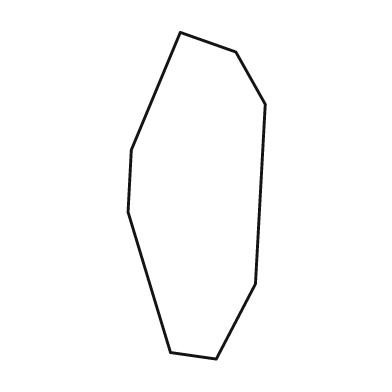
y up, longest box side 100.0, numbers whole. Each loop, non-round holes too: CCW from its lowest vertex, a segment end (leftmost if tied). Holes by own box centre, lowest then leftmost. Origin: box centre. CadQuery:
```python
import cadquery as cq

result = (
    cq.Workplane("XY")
    .moveTo(6.0, -50.0)
    .lineTo(18.0, -27.0)
    .lineTo(21.0, 28.0)
    .lineTo(12.0, 44.0)
    .lineTo(-5.0, 50.0)
    .lineTo(-20.0, 14.0)
    .lineTo(-21.0, -5.0)
    .lineTo(-8.0, -48.0)
    .close()
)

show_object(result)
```